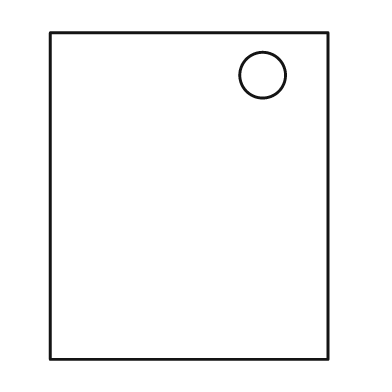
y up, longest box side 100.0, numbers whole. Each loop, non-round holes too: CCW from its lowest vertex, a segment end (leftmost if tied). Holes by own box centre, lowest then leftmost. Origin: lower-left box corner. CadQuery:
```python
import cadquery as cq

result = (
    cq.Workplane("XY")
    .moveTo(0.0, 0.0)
    .lineTo(85.0, 0.0)
    .lineTo(85.0, 100.0)
    .lineTo(0.0, 100.0)
    .close()
    .moveTo(65.0, 87.0)
    .circle(7.0)
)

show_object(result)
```